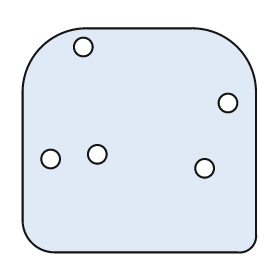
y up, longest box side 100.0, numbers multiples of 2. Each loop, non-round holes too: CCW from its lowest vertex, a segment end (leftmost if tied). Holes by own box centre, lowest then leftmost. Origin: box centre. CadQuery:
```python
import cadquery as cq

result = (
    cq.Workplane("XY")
    .moveTo(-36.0, -48.0)
    .lineTo(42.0, -48.0)
    .threePointArc((48.0, -46.0), (50.0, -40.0))
    .lineTo(50.0, 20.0)
    .threePointArc((42.0, 40.0), (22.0, 48.0))
    .lineTo(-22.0, 48.0)
    .threePointArc((-42.0, 40.0), (-50.0, 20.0))
    .lineTo(-50.0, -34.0)
    .threePointArc((-46.0, -44.0), (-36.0, -48.0))
    .close()
    .moveTo(28.0, -12.0)
    .circle(4.0)
    .moveTo(-38.0, -8.0)
    .circle(4.0)
    .moveTo(-18.0, -6.0)
    .circle(4.0)
    .moveTo(38.0, 16.0)
    .circle(4.0)
    .moveTo(-24.0, 40.0)
    .circle(4.0)
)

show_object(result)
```